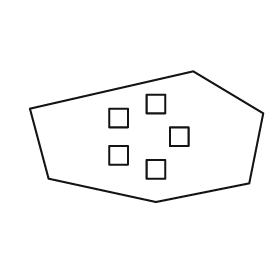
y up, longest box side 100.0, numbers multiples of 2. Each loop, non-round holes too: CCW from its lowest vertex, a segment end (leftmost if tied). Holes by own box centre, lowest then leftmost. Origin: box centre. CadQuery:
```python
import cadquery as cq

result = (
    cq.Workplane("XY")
    .moveTo(4.0, -28.0)
    .lineTo(44.0, -20.0)
    .lineTo(50.0, 10.0)
    .lineTo(20.0, 28.0)
    .lineTo(-50.0, 12.0)
    .lineTo(-42.0, -18.0)
    .close()
    .moveTo(0.0, -18.0)
    .lineTo(8.0, -18.0)
    .lineTo(8.0, -10.0)
    .lineTo(0.0, -10.0)
    .close()
    .moveTo(-16.0, -12.0)
    .lineTo(-8.0, -12.0)
    .lineTo(-8.0, -4.0)
    .lineTo(-16.0, -4.0)
    .close()
    .moveTo(10.0, -4.0)
    .lineTo(18.0, -4.0)
    .lineTo(18.0, 4.0)
    .lineTo(10.0, 4.0)
    .close()
    .moveTo(-16.0, 4.0)
    .lineTo(-8.0, 4.0)
    .lineTo(-8.0, 12.0)
    .lineTo(-16.0, 12.0)
    .close()
    .moveTo(0.0, 10.0)
    .lineTo(8.0, 10.0)
    .lineTo(8.0, 18.0)
    .lineTo(0.0, 18.0)
    .close()
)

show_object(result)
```